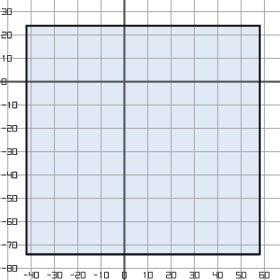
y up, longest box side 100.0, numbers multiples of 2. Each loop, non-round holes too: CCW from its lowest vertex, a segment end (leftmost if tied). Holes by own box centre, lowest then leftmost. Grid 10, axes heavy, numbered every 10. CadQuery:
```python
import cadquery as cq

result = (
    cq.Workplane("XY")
    .moveTo(-42.0, -74.0)
    .lineTo(58.0, -74.0)
    .lineTo(58.0, 24.0)
    .lineTo(-42.0, 24.0)
    .close()
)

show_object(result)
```